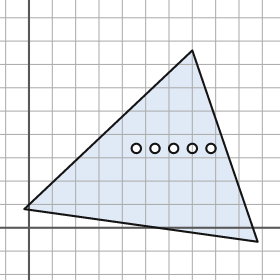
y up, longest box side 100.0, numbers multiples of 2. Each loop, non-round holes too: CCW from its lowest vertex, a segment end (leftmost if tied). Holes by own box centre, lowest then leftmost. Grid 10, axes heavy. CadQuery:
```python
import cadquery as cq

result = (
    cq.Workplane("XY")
    .moveTo(98.0, -6.0)
    .lineTo(70.0, 76.0)
    .lineTo(-2.0, 8.0)
    .close()
    .moveTo(46.0, 34.0)
    .circle(2.0)
    .moveTo(54.0, 34.0)
    .circle(2.0)
    .moveTo(62.0, 34.0)
    .circle(2.0)
    .moveTo(70.0, 34.0)
    .circle(2.0)
    .moveTo(78.0, 34.0)
    .circle(2.0)
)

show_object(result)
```